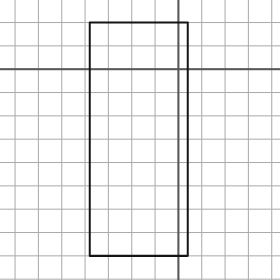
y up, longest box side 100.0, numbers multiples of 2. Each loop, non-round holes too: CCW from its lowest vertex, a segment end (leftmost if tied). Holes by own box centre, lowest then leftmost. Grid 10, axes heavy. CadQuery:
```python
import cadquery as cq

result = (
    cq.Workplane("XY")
    .moveTo(-38.0, -80.0)
    .lineTo(4.0, -80.0)
    .lineTo(4.0, 20.0)
    .lineTo(-38.0, 20.0)
    .close()
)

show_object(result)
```